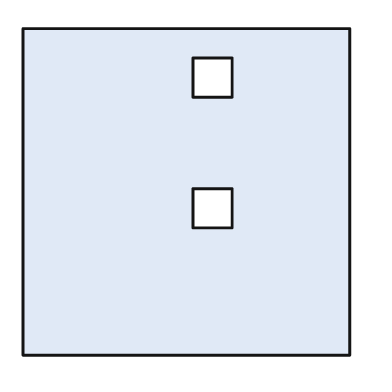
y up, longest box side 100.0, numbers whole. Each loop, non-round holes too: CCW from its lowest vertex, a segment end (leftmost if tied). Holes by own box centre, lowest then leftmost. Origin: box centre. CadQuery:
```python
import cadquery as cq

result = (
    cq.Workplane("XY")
    .moveTo(-50.0, -50.0)
    .lineTo(50.0, -50.0)
    .lineTo(50.0, 50.0)
    .lineTo(-50.0, 50.0)
    .close()
    .moveTo(2.0, -11.0)
    .lineTo(14.0, -11.0)
    .lineTo(14.0, 1.0)
    .lineTo(2.0, 1.0)
    .close()
    .moveTo(2.0, 29.0)
    .lineTo(14.0, 29.0)
    .lineTo(14.0, 41.0)
    .lineTo(2.0, 41.0)
    .close()
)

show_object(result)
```